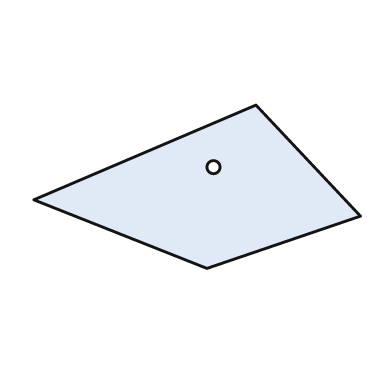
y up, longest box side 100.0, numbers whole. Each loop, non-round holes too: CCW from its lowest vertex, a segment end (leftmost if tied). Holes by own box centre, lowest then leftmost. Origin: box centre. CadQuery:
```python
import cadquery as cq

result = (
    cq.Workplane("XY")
    .moveTo(3.0, -25.0)
    .lineTo(50.0, -9.0)
    .lineTo(18.0, 25.0)
    .lineTo(-50.0, -4.0)
    .close()
    .moveTo(5.0, 6.0)
    .circle(2.0)
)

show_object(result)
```